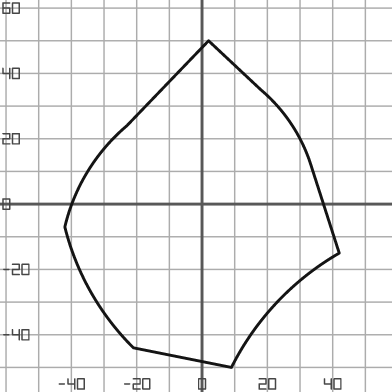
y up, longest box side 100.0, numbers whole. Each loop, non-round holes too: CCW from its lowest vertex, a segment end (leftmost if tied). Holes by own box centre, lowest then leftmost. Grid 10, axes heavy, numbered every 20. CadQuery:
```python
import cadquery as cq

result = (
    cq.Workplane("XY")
    .moveTo(9.0, -50.0)
    .threePointArc((23.0, -30.0), (42.0, -15.0))
    .lineTo(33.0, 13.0)
    .threePointArc((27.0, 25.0), (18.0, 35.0))
    .lineTo(2.0, 50.0)
    .lineTo(-23.0, 24.0)
    .threePointArc((-35.0, 10.0), (-42.0, -7.0))
    .threePointArc((-34.0, -27.0), (-21.0, -44.0))
    .close()
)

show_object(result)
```